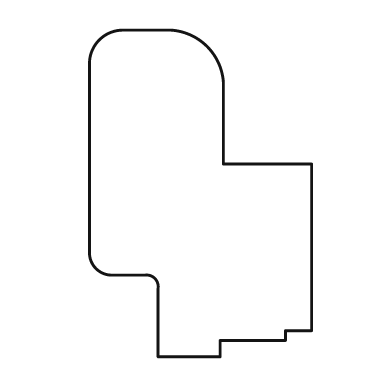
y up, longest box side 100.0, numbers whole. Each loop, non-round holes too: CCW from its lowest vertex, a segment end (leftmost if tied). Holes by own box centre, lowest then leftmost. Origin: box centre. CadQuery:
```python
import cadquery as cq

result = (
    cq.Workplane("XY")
    .moveTo(-13.0, -50.0)
    .lineTo(6.0, -50.0)
    .lineTo(6.0, -45.0)
    .lineTo(26.0, -45.0)
    .lineTo(26.0, -42.0)
    .lineTo(34.0, -42.0)
    .lineTo(34.0, 9.0)
    .lineTo(7.0, 9.0)
    .lineTo(7.0, 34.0)
    .threePointArc((2.0, 45.0), (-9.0, 50.0))
    .lineTo(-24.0, 50.0)
    .threePointArc((-31.0, 47.0), (-34.0, 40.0))
    .lineTo(-34.0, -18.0)
    .threePointArc((-32.0, -23.0), (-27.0, -25.0))
    .lineTo(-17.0, -25.0)
    .threePointArc((-14.0, -26.0), (-13.0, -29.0))
    .close()
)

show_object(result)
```